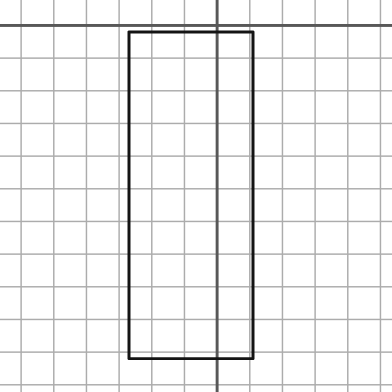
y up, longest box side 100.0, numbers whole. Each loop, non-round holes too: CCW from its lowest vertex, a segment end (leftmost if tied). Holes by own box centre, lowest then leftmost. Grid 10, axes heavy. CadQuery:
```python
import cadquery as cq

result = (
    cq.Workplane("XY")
    .moveTo(-27.0, -102.0)
    .lineTo(11.0, -102.0)
    .lineTo(11.0, -2.0)
    .lineTo(-27.0, -2.0)
    .close()
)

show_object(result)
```